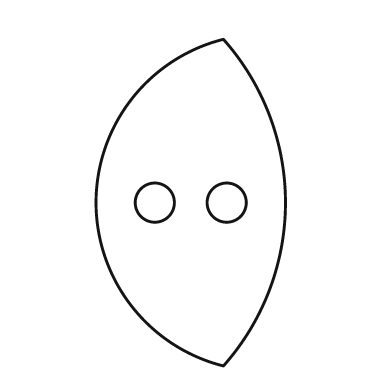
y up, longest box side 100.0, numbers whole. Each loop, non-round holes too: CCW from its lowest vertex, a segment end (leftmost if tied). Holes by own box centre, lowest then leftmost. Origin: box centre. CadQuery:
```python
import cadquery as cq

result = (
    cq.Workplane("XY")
    .moveTo(10.0, -50.0)
    .threePointArc((29.0, 0.0), (10.0, 50.0))
    .threePointArc((-29.0, 0.0), (10.0, -50.0))
    .close()
    .moveTo(-11.0, 0.0)
    .circle(6.0)
    .moveTo(11.0, 0.0)
    .circle(6.0)
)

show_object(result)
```